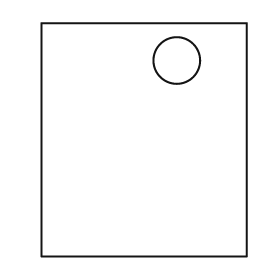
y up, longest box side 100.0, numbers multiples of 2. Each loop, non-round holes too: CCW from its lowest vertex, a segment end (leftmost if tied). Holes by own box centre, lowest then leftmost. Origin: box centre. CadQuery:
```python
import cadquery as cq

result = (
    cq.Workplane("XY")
    .moveTo(-44.0, -50.0)
    .lineTo(44.0, -50.0)
    .lineTo(44.0, 50.0)
    .lineTo(-44.0, 50.0)
    .close()
    .moveTo(14.0, 34.0)
    .circle(10.0)
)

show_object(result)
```